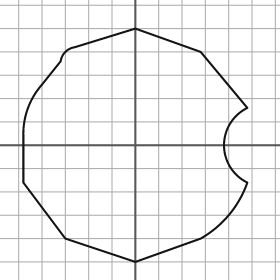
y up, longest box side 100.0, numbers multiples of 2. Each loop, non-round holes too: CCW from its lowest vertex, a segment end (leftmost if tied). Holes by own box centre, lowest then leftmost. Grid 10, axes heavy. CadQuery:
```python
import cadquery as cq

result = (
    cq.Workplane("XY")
    .moveTo(0.0, -50.0)
    .lineTo(28.0, -40.0)
    .threePointArc((40.0, -30.0), (48.0, -16.0))
    .threePointArc((38.0, 0.0), (48.0, 16.0))
    .lineTo(28.0, 40.0)
    .lineTo(0.0, 50.0)
    .lineTo(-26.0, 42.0)
    .threePointArc((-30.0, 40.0), (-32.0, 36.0))
    .lineTo(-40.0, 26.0)
    .threePointArc((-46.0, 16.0), (-48.0, 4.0))
    .lineTo(-48.0, -16.0)
    .lineTo(-30.0, -40.0)
    .close()
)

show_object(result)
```